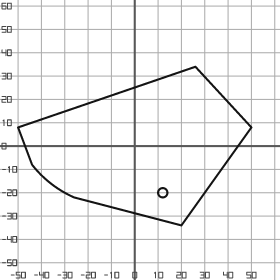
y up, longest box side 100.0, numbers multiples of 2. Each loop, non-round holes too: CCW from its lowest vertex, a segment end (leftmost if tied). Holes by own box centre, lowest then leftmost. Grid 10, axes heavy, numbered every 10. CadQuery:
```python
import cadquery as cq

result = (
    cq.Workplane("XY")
    .moveTo(20.0, -34.0)
    .lineTo(50.0, 8.0)
    .lineTo(26.0, 34.0)
    .lineTo(-50.0, 8.0)
    .lineTo(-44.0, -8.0)
    .threePointArc((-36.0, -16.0), (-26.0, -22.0))
    .close()
    .moveTo(12.0, -20.0)
    .circle(2.0)
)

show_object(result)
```